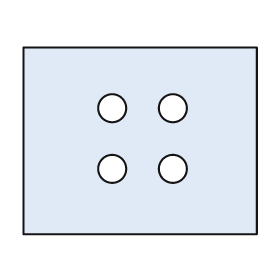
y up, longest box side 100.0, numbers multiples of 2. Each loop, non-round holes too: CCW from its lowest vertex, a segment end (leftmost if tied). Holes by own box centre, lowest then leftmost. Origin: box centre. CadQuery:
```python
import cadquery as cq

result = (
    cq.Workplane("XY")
    .moveTo(-50.0, -40.0)
    .lineTo(50.0, -40.0)
    .lineTo(50.0, 40.0)
    .lineTo(-50.0, 40.0)
    .close()
    .moveTo(-12.0, -12.0)
    .circle(6.0)
    .moveTo(14.0, -12.0)
    .circle(6.0)
    .moveTo(-12.0, 14.0)
    .circle(6.0)
    .moveTo(14.0, 14.0)
    .circle(6.0)
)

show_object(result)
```